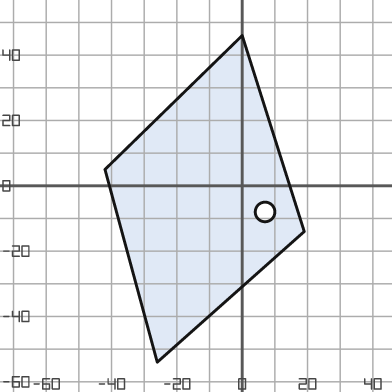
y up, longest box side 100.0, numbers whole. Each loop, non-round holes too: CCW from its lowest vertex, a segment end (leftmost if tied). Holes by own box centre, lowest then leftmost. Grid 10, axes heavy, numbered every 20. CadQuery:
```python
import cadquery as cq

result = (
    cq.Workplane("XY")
    .moveTo(-26.0, -54.0)
    .lineTo(19.0, -14.0)
    .lineTo(0.0, 46.0)
    .lineTo(-42.0, 5.0)
    .close()
    .moveTo(7.0, -8.0)
    .circle(3.0)
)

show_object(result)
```